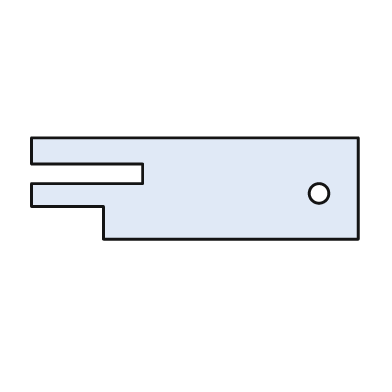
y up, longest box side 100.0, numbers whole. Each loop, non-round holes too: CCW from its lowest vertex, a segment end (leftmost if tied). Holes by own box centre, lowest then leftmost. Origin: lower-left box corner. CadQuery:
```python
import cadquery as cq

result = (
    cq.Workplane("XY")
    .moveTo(22.0, 0.0)
    .lineTo(100.0, 0.0)
    .lineTo(100.0, 31.0)
    .lineTo(0.0, 31.0)
    .lineTo(0.0, 23.0)
    .lineTo(34.0, 23.0)
    .lineTo(34.0, 17.0)
    .lineTo(0.0, 17.0)
    .lineTo(0.0, 10.0)
    .lineTo(22.0, 10.0)
    .close()
    .moveTo(88.0, 14.0)
    .circle(3.0)
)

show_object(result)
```